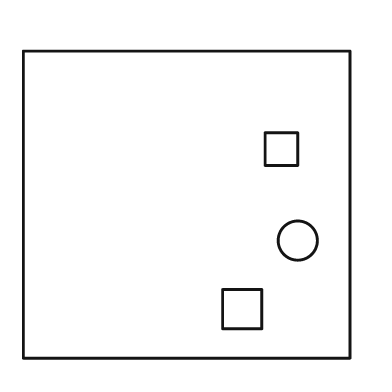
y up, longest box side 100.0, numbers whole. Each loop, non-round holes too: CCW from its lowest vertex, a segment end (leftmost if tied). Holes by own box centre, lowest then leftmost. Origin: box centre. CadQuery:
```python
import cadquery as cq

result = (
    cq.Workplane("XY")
    .moveTo(-50.0, -47.0)
    .lineTo(50.0, -47.0)
    .lineTo(50.0, 47.0)
    .lineTo(-50.0, 47.0)
    .close()
    .moveTo(11.0, -38.0)
    .lineTo(23.0, -38.0)
    .lineTo(23.0, -26.0)
    .lineTo(11.0, -26.0)
    .close()
    .moveTo(34.0, -11.0)
    .circle(6.0)
    .moveTo(24.0, 12.0)
    .lineTo(34.0, 12.0)
    .lineTo(34.0, 22.0)
    .lineTo(24.0, 22.0)
    .close()
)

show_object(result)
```